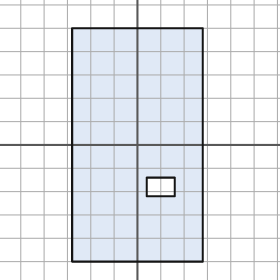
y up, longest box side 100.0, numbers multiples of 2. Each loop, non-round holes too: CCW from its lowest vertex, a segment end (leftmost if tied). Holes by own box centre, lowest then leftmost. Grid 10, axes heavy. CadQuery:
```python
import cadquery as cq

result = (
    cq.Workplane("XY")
    .moveTo(-28.0, -50.0)
    .lineTo(28.0, -50.0)
    .lineTo(28.0, 50.0)
    .lineTo(-28.0, 50.0)
    .close()
    .moveTo(4.0, -22.0)
    .lineTo(16.0, -22.0)
    .lineTo(16.0, -14.0)
    .lineTo(4.0, -14.0)
    .close()
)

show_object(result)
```